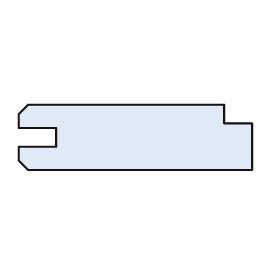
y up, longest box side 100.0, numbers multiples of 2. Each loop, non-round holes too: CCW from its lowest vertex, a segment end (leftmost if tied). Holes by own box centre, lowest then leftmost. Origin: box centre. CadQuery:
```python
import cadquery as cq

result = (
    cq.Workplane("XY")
    .moveTo(-46.0, -14.0)
    .lineTo(50.0, -14.0)
    .lineTo(50.0, 6.0)
    .lineTo(38.0, 6.0)
    .lineTo(38.0, 14.0)
    .lineTo(-46.0, 14.0)
    .lineTo(-50.0, 10.0)
    .lineTo(-50.0, 4.0)
    .lineTo(-34.0, 4.0)
    .lineTo(-34.0, -4.0)
    .lineTo(-50.0, -4.0)
    .lineTo(-50.0, -10.0)
    .close()
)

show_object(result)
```